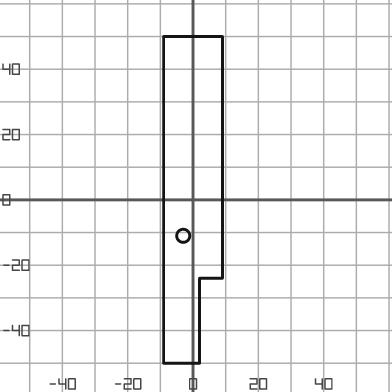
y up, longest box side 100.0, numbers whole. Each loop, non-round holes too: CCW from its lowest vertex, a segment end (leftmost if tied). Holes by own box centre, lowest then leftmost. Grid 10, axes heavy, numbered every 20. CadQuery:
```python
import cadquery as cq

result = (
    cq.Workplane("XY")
    .moveTo(-9.0, -50.0)
    .lineTo(2.0, -50.0)
    .lineTo(2.0, -24.0)
    .lineTo(9.0, -24.0)
    .lineTo(9.0, 50.0)
    .lineTo(-9.0, 50.0)
    .close()
    .moveTo(-3.0, -11.0)
    .circle(2.0)
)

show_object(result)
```